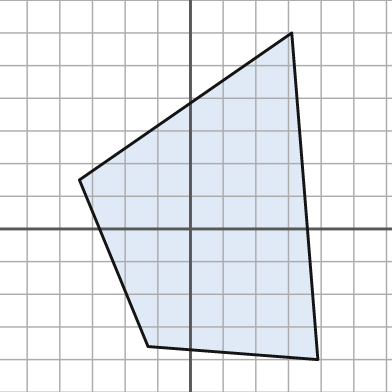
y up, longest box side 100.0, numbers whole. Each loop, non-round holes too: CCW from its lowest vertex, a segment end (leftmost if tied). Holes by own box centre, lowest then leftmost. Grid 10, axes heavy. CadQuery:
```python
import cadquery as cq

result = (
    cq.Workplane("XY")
    .moveTo(39.0, -40.0)
    .lineTo(31.0, 60.0)
    .lineTo(-34.0, 15.0)
    .lineTo(-13.0, -36.0)
    .close()
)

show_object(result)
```